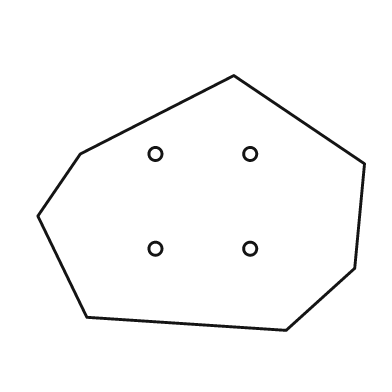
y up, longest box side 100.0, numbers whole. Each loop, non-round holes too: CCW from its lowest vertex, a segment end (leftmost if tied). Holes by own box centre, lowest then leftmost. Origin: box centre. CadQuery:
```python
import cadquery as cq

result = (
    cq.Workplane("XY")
    .moveTo(26.0, -39.0)
    .lineTo(47.0, -20.0)
    .lineTo(50.0, 12.0)
    .lineTo(10.0, 39.0)
    .lineTo(-37.0, 15.0)
    .lineTo(-50.0, -4.0)
    .lineTo(-35.0, -35.0)
    .close()
    .moveTo(-14.0, -14.0)
    .circle(2.0)
    .moveTo(15.0, -14.0)
    .circle(2.0)
    .moveTo(-14.0, 15.0)
    .circle(2.0)
    .moveTo(15.0, 15.0)
    .circle(2.0)
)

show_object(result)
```